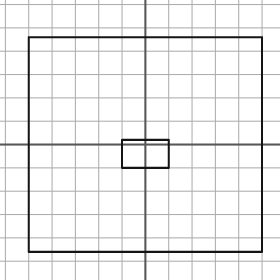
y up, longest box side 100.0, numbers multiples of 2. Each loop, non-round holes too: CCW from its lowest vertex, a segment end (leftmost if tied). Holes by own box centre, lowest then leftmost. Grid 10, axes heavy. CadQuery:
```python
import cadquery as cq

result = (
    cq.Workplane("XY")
    .moveTo(-50.0, -46.0)
    .lineTo(50.0, -46.0)
    .lineTo(50.0, 46.0)
    .lineTo(-50.0, 46.0)
    .close()
    .moveTo(-10.0, -10.0)
    .lineTo(10.0, -10.0)
    .lineTo(10.0, 2.0)
    .lineTo(-10.0, 2.0)
    .close()
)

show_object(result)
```